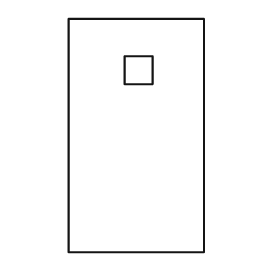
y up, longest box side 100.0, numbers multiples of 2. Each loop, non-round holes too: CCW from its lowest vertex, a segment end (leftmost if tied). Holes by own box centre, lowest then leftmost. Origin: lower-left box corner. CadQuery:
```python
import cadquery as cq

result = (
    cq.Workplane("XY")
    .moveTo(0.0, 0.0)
    .lineTo(58.0, 0.0)
    .lineTo(58.0, 100.0)
    .lineTo(0.0, 100.0)
    .close()
    .moveTo(24.0, 72.0)
    .lineTo(36.0, 72.0)
    .lineTo(36.0, 84.0)
    .lineTo(24.0, 84.0)
    .close()
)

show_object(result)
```